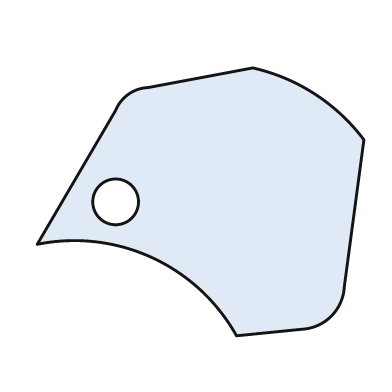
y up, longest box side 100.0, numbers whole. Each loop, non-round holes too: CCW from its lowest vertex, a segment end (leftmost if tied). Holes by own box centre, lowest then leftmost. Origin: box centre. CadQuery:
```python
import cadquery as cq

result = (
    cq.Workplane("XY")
    .moveTo(11.0, -41.0)
    .lineTo(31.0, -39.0)
    .threePointArc((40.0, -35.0), (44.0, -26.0))
    .lineTo(50.0, 19.0)
    .threePointArc((35.0, 33.0), (16.0, 41.0))
    .lineTo(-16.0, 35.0)
    .threePointArc((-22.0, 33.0), (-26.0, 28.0))
    .lineTo(-50.0, -13.0)
    .threePointArc((-15.0, -17.0), (11.0, -41.0))
    .close()
    .moveTo(-26.0, 0.0)
    .circle(7.0)
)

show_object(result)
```